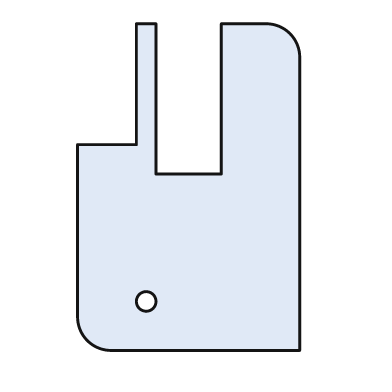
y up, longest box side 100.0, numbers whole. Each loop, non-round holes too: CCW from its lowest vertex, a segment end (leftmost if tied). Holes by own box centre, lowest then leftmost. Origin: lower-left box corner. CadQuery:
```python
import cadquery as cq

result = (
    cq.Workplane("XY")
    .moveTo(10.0, 0.0)
    .lineTo(68.0, 0.0)
    .lineTo(68.0, 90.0)
    .threePointArc((65.0, 97.0), (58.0, 100.0))
    .lineTo(44.0, 100.0)
    .lineTo(44.0, 54.0)
    .lineTo(24.0, 54.0)
    .lineTo(24.0, 100.0)
    .lineTo(18.0, 100.0)
    .lineTo(18.0, 63.0)
    .lineTo(0.0, 63.0)
    .lineTo(0.0, 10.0)
    .threePointArc((3.0, 3.0), (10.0, 0.0))
    .close()
    .moveTo(21.0, 15.0)
    .circle(3.0)
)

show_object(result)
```